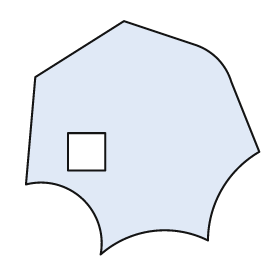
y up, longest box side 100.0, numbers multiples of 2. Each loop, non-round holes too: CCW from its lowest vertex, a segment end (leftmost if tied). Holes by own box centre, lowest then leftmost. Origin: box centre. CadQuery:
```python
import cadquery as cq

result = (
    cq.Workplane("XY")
    .moveTo(-18.0, -50.0)
    .threePointArc((4.0, -40.0), (28.0, -44.0))
    .threePointArc((34.0, -22.0), (50.0, -6.0))
    .lineTo(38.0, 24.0)
    .threePointArc((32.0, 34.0), (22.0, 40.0))
    .lineTo(-8.0, 50.0)
    .lineTo(-46.0, 26.0)
    .lineTo(-50.0, -20.0)
    .threePointArc((-26.0, -26.0), (-18.0, -50.0))
    .close()
    .moveTo(-32.0, -14.0)
    .lineTo(-16.0, -14.0)
    .lineTo(-16.0, 2.0)
    .lineTo(-32.0, 2.0)
    .close()
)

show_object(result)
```